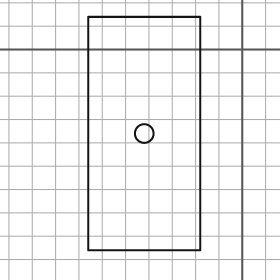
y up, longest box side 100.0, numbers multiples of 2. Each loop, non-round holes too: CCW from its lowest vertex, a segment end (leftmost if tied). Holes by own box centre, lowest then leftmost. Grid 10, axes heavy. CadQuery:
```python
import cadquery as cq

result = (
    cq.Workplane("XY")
    .moveTo(-66.0, -86.0)
    .lineTo(-18.0, -86.0)
    .lineTo(-18.0, 14.0)
    .lineTo(-66.0, 14.0)
    .close()
    .moveTo(-42.0, -36.0)
    .circle(4.0)
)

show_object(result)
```